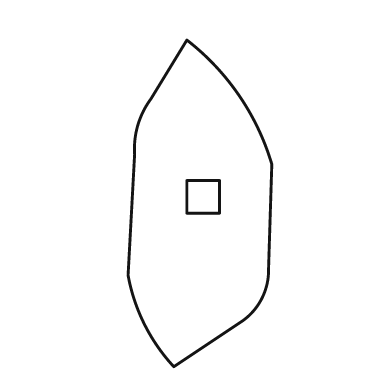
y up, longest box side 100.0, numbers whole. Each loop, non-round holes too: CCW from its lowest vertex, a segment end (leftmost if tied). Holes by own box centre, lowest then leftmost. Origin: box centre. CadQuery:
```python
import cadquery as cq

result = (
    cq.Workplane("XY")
    .moveTo(-8.0, -50.0)
    .lineTo(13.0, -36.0)
    .threePointArc((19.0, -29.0), (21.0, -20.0))
    .lineTo(22.0, 12.0)
    .threePointArc((12.0, 33.0), (-4.0, 50.0))
    .lineTo(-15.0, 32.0)
    .threePointArc((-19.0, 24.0), (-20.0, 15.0))
    .lineTo(-22.0, -22.0)
    .threePointArc((-17.0, -37.0), (-8.0, -50.0))
    .close()
    .moveTo(-4.0, -3.0)
    .lineTo(6.0, -3.0)
    .lineTo(6.0, 7.0)
    .lineTo(-4.0, 7.0)
    .close()
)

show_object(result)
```